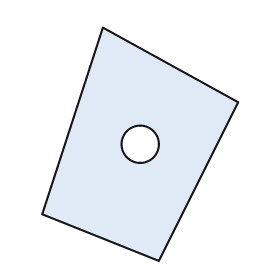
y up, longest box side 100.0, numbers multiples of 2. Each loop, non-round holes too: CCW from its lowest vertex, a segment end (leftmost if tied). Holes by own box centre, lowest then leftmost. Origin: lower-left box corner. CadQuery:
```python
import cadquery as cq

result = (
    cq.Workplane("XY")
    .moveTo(50.0, 0.0)
    .lineTo(84.0, 68.0)
    .lineTo(26.0, 100.0)
    .lineTo(0.0, 20.0)
    .close()
    .moveTo(42.0, 50.0)
    .circle(8.0)
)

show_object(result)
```